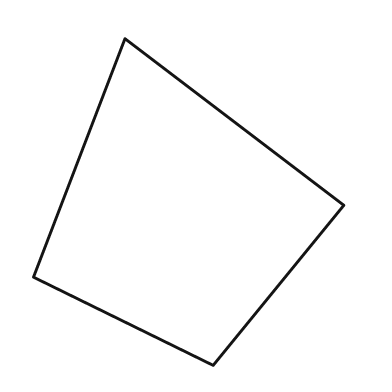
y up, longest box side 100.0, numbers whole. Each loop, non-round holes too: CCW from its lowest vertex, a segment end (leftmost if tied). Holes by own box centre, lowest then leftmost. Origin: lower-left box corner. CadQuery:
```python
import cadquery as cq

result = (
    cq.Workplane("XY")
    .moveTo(55.0, 0.0)
    .lineTo(95.0, 49.0)
    .lineTo(28.0, 100.0)
    .lineTo(0.0, 27.0)
    .close()
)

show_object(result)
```